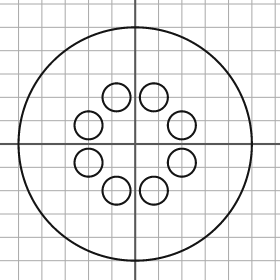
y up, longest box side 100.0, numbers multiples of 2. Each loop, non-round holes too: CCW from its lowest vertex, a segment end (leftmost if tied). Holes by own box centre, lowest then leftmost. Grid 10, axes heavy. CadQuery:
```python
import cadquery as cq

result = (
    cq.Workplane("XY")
    .moveTo(0.0, 0.0)
    .circle(50.0)
    .moveTo(-8.0, -20.0)
    .circle(6.0)
    .moveTo(8.0, -20.0)
    .circle(6.0)
    .moveTo(-20.0, -8.0)
    .circle(6.0)
    .moveTo(20.0, -8.0)
    .circle(6.0)
    .moveTo(-20.0, 8.0)
    .circle(6.0)
    .moveTo(20.0, 8.0)
    .circle(6.0)
    .moveTo(-8.0, 20.0)
    .circle(6.0)
    .moveTo(8.0, 20.0)
    .circle(6.0)
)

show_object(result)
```